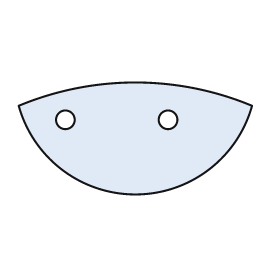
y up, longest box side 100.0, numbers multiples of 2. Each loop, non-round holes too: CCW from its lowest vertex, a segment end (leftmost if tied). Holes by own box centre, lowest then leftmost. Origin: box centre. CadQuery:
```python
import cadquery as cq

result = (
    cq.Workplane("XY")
    .moveTo(-50.0, 14.0)
    .threePointArc((0.0, -24.0), (50.0, 14.0))
    .threePointArc((0.0, 24.0), (-50.0, 14.0))
    .close()
    .moveTo(-30.0, 8.0)
    .circle(4.0)
    .moveTo(14.0, 8.0)
    .circle(4.0)
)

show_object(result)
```